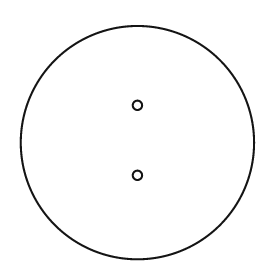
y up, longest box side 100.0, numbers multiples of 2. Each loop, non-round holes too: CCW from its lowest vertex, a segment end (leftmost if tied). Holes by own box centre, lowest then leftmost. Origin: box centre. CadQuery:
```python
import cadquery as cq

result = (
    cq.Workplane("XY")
    .moveTo(0.0, 0.0)
    .circle(50.0)
    .moveTo(0.0, -14.0)
    .circle(2.0)
    .moveTo(0.0, 16.0)
    .circle(2.0)
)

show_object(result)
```